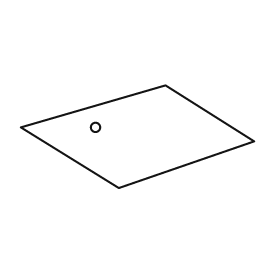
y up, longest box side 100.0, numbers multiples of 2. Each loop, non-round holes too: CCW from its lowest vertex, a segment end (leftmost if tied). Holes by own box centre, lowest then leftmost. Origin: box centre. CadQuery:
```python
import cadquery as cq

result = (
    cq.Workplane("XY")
    .moveTo(-8.0, -22.0)
    .lineTo(50.0, -2.0)
    .lineTo(12.0, 22.0)
    .lineTo(-50.0, 4.0)
    .close()
    .moveTo(-18.0, 4.0)
    .circle(2.0)
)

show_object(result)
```